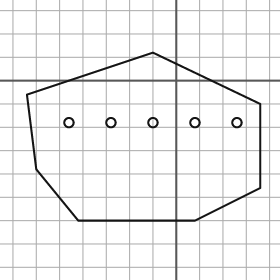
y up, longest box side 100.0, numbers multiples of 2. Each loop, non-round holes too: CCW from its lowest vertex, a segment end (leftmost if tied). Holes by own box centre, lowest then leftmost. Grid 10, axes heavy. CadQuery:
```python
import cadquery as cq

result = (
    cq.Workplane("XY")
    .moveTo(-42.0, -60.0)
    .lineTo(8.0, -60.0)
    .lineTo(36.0, -46.0)
    .lineTo(36.0, -10.0)
    .lineTo(-10.0, 12.0)
    .lineTo(-64.0, -6.0)
    .lineTo(-60.0, -38.0)
    .close()
    .moveTo(-46.0, -18.0)
    .circle(2.0)
    .moveTo(-28.0, -18.0)
    .circle(2.0)
    .moveTo(-10.0, -18.0)
    .circle(2.0)
    .moveTo(8.0, -18.0)
    .circle(2.0)
    .moveTo(26.0, -18.0)
    .circle(2.0)
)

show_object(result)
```